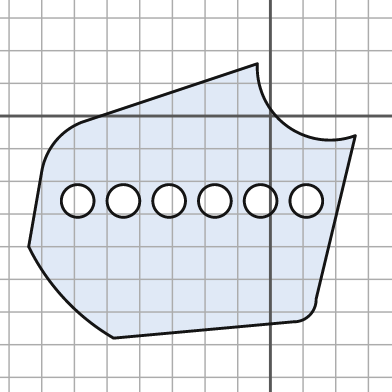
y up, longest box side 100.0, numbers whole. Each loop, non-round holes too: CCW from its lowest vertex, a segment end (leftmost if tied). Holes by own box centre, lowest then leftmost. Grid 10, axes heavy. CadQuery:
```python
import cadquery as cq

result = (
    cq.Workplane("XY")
    .moveTo(-48.0, -68.0)
    .lineTo(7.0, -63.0)
    .threePointArc((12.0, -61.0), (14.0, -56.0))
    .lineTo(26.0, -6.0)
    .threePointArc((5.0, -3.0), (-4.0, 16.0))
    .lineTo(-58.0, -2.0)
    .threePointArc((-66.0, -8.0), (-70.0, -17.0))
    .lineTo(-74.0, -40.0)
    .threePointArc((-63.0, -56.0), (-48.0, -68.0))
    .close()
    .moveTo(-59.0, -26.0)
    .circle(5.0)
    .moveTo(-45.0, -26.0)
    .circle(5.0)
    .moveTo(-31.0, -26.0)
    .circle(5.0)
    .moveTo(-17.0, -26.0)
    .circle(5.0)
    .moveTo(-3.0, -26.0)
    .circle(5.0)
    .moveTo(11.0, -26.0)
    .circle(5.0)
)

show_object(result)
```